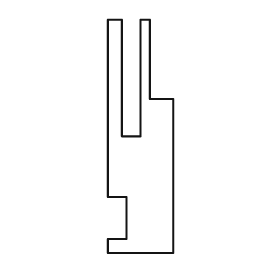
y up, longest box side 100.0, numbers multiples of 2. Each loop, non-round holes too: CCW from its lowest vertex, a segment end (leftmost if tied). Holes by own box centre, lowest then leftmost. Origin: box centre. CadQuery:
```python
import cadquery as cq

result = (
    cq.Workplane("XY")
    .moveTo(-14.0, -50.0)
    .lineTo(14.0, -50.0)
    .lineTo(14.0, 16.0)
    .lineTo(4.0, 16.0)
    .lineTo(4.0, 50.0)
    .lineTo(0.0, 50.0)
    .lineTo(0.0, 0.0)
    .lineTo(-8.0, 0.0)
    .lineTo(-8.0, 50.0)
    .lineTo(-14.0, 50.0)
    .lineTo(-14.0, -26.0)
    .lineTo(-6.0, -26.0)
    .lineTo(-6.0, -44.0)
    .lineTo(-14.0, -44.0)
    .close()
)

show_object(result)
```